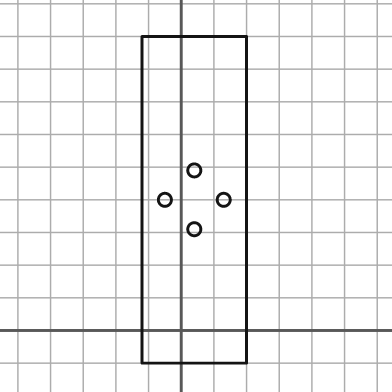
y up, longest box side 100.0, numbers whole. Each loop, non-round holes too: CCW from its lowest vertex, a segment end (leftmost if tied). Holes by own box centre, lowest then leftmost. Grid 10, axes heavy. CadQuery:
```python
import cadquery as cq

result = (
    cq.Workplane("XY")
    .moveTo(-12.0, -10.0)
    .lineTo(20.0, -10.0)
    .lineTo(20.0, 90.0)
    .lineTo(-12.0, 90.0)
    .close()
    .moveTo(4.0, 31.0)
    .circle(2.0)
    .moveTo(-5.0, 40.0)
    .circle(2.0)
    .moveTo(13.0, 40.0)
    .circle(2.0)
    .moveTo(4.0, 49.0)
    .circle(2.0)
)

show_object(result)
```